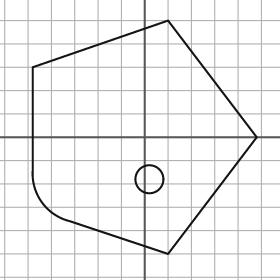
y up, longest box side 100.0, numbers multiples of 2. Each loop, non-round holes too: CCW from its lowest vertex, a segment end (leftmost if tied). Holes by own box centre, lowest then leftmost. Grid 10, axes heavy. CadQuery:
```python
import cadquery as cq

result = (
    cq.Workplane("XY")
    .moveTo(10.0, -50.0)
    .lineTo(48.0, 0.0)
    .lineTo(10.0, 50.0)
    .lineTo(-48.0, 30.0)
    .lineTo(-48.0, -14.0)
    .threePointArc((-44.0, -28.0), (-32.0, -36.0))
    .close()
    .moveTo(2.0, -18.0)
    .circle(6.0)
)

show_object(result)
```